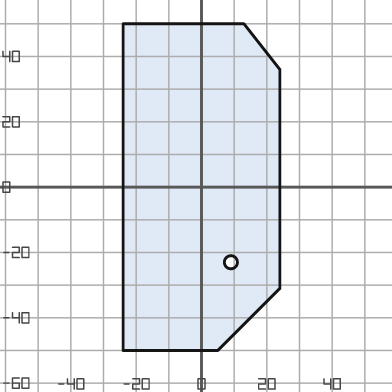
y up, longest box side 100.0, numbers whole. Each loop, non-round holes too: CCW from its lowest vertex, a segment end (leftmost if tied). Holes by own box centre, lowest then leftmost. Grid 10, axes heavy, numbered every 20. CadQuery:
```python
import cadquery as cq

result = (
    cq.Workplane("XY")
    .moveTo(-24.0, -50.0)
    .lineTo(5.0, -50.0)
    .lineTo(24.0, -31.0)
    .lineTo(24.0, 36.0)
    .lineTo(13.0, 50.0)
    .lineTo(-24.0, 50.0)
    .close()
    .moveTo(9.0, -23.0)
    .circle(2.0)
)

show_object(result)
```